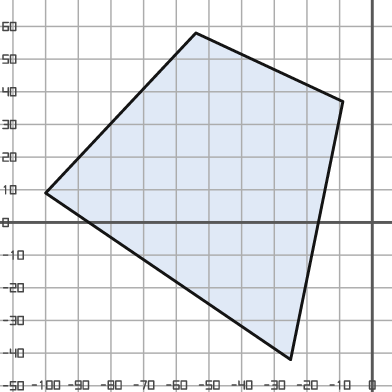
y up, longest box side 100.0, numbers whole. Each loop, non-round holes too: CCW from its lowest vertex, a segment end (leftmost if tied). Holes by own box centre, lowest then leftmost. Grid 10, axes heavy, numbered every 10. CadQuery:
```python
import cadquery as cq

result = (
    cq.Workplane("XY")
    .moveTo(-25.0, -42.0)
    .lineTo(-9.0, 37.0)
    .lineTo(-54.0, 58.0)
    .lineTo(-100.0, 9.0)
    .close()
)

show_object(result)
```